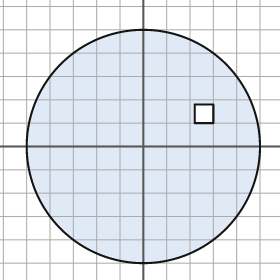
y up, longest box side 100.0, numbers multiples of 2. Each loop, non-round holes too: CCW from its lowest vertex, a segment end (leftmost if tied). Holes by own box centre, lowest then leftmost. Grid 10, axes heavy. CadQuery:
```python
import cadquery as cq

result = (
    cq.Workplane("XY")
    .moveTo(0.0, 0.0)
    .circle(50.0)
    .moveTo(22.0, 10.0)
    .lineTo(30.0, 10.0)
    .lineTo(30.0, 18.0)
    .lineTo(22.0, 18.0)
    .close()
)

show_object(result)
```